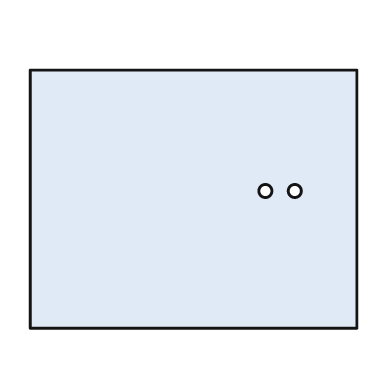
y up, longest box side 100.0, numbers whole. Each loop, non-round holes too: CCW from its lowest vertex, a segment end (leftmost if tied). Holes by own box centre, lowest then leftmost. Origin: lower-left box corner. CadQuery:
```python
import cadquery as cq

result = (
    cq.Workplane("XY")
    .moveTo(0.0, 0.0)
    .lineTo(100.0, 0.0)
    .lineTo(100.0, 79.0)
    .lineTo(0.0, 79.0)
    .close()
    .moveTo(72.0, 42.0)
    .circle(2.0)
    .moveTo(81.0, 42.0)
    .circle(2.0)
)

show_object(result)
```